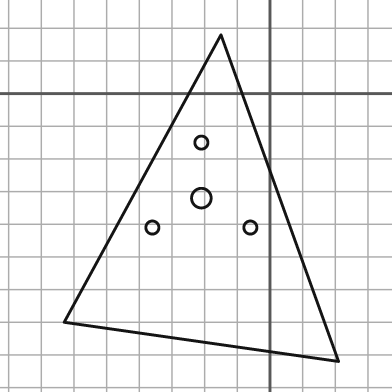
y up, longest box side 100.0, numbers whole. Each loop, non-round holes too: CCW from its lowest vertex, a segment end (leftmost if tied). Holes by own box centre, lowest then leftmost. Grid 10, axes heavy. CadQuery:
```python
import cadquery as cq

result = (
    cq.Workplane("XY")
    .moveTo(21.0, -82.0)
    .lineTo(-15.0, 18.0)
    .lineTo(-63.0, -70.0)
    .close()
    .moveTo(-36.0, -41.0)
    .circle(2.0)
    .moveTo(-6.0, -41.0)
    .circle(2.0)
    .moveTo(-21.0, -32.0)
    .circle(3.0)
    .moveTo(-21.0, -15.0)
    .circle(2.0)
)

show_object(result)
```